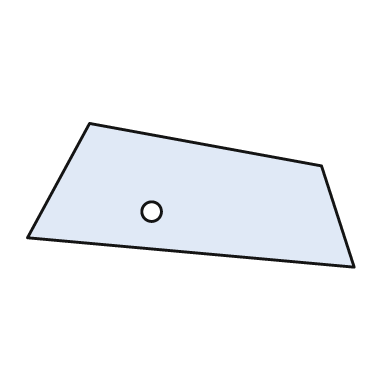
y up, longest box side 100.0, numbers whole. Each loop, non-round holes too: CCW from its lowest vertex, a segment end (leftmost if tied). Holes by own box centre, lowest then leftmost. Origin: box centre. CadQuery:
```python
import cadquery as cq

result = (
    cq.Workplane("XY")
    .moveTo(50.0, -22.0)
    .lineTo(40.0, 9.0)
    .lineTo(-31.0, 22.0)
    .lineTo(-50.0, -13.0)
    .close()
    .moveTo(-12.0, -5.0)
    .circle(3.0)
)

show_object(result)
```